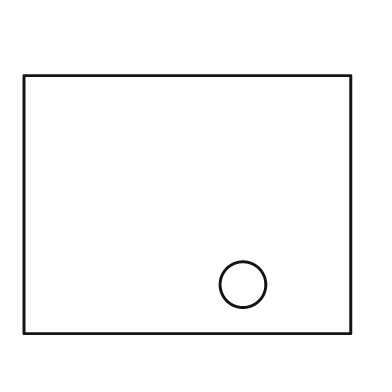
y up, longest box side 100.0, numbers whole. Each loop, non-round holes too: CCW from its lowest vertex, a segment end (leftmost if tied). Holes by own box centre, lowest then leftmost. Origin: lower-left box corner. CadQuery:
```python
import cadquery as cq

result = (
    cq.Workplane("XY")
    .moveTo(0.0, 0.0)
    .lineTo(100.0, 0.0)
    .lineTo(100.0, 79.0)
    .lineTo(0.0, 79.0)
    .close()
    .moveTo(67.0, 15.0)
    .circle(7.0)
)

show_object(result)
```